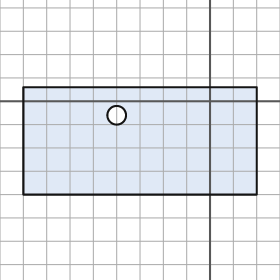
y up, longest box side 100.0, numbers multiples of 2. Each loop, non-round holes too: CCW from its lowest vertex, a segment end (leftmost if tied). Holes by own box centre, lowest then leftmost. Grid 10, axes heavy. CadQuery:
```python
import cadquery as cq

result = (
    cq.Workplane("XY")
    .moveTo(-80.0, -40.0)
    .lineTo(20.0, -40.0)
    .lineTo(20.0, 6.0)
    .lineTo(-80.0, 6.0)
    .close()
    .moveTo(-40.0, -6.0)
    .circle(4.0)
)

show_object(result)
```